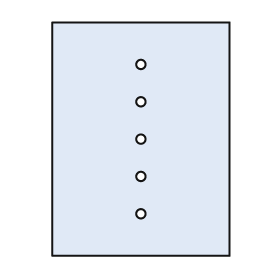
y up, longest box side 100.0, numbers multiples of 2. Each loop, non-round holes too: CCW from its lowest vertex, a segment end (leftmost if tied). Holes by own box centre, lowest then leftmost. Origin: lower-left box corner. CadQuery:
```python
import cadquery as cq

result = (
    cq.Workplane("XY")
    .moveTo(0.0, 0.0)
    .lineTo(76.0, 0.0)
    .lineTo(76.0, 100.0)
    .lineTo(0.0, 100.0)
    .close()
    .moveTo(38.0, 18.0)
    .circle(2.0)
    .moveTo(38.0, 34.0)
    .circle(2.0)
    .moveTo(38.0, 50.0)
    .circle(2.0)
    .moveTo(38.0, 66.0)
    .circle(2.0)
    .moveTo(38.0, 82.0)
    .circle(2.0)
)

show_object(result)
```